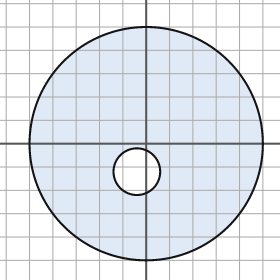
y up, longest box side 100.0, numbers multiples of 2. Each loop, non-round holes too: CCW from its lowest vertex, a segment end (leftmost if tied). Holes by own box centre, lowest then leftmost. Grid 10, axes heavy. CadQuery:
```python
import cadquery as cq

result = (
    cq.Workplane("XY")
    .moveTo(0.0, 0.0)
    .circle(50.0)
    .moveTo(-4.0, -12.0)
    .circle(10.0)
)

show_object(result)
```